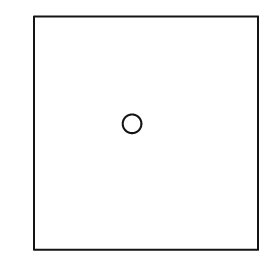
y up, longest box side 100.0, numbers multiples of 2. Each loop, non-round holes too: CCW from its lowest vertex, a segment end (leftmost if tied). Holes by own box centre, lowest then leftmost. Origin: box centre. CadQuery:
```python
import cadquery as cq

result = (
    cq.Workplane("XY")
    .moveTo(-48.0, -50.0)
    .lineTo(48.0, -50.0)
    .lineTo(48.0, 50.0)
    .lineTo(-48.0, 50.0)
    .close()
    .moveTo(-6.0, 4.0)
    .circle(4.0)
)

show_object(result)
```